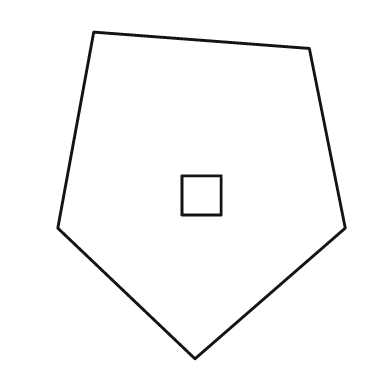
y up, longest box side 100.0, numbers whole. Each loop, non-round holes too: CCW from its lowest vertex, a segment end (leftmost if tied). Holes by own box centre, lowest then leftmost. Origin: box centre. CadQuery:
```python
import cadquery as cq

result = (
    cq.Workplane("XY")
    .moveTo(-2.0, -50.0)
    .lineTo(44.0, -10.0)
    .lineTo(33.0, 45.0)
    .lineTo(-33.0, 50.0)
    .lineTo(-44.0, -10.0)
    .close()
    .moveTo(-6.0, -6.0)
    .lineTo(6.0, -6.0)
    .lineTo(6.0, 6.0)
    .lineTo(-6.0, 6.0)
    .close()
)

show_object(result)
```